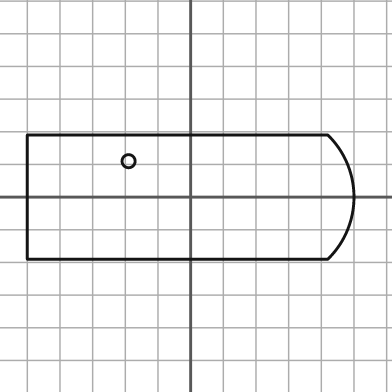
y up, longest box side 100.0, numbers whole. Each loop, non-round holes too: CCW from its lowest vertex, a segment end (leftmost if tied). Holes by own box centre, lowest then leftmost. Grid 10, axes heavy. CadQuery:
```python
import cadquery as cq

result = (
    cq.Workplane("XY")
    .moveTo(-50.0, -19.0)
    .lineTo(42.0, -19.0)
    .threePointArc((50.0, 0.0), (42.0, 19.0))
    .lineTo(-50.0, 19.0)
    .close()
    .moveTo(-19.0, 11.0)
    .circle(2.0)
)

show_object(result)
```